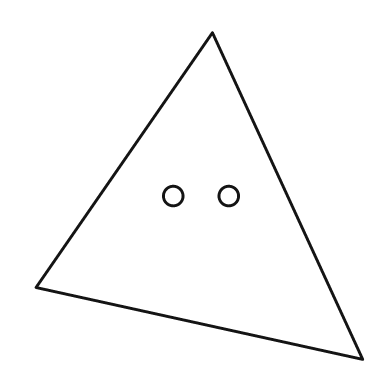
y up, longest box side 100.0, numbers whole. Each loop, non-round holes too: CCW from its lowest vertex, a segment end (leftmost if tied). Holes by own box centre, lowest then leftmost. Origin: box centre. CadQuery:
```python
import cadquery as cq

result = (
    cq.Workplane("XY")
    .moveTo(50.0, -50.0)
    .lineTo(4.0, 50.0)
    .lineTo(-50.0, -28.0)
    .close()
    .moveTo(-8.0, 0.0)
    .circle(3.0)
    .moveTo(9.0, 0.0)
    .circle(3.0)
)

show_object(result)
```